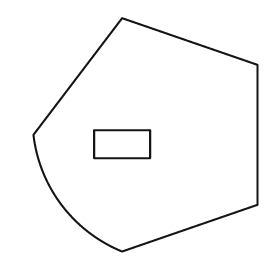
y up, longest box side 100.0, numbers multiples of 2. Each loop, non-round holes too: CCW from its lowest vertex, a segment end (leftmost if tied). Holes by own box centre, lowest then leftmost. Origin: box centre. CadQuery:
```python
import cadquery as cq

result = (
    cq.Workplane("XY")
    .moveTo(-10.0, -50.0)
    .lineTo(48.0, -30.0)
    .lineTo(48.0, 30.0)
    .lineTo(-10.0, 50.0)
    .lineTo(-48.0, 0.0)
    .threePointArc((-36.0, -30.0), (-10.0, -50.0))
    .close()
    .moveTo(-22.0, -10.0)
    .lineTo(2.0, -10.0)
    .lineTo(2.0, 2.0)
    .lineTo(-22.0, 2.0)
    .close()
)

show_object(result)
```